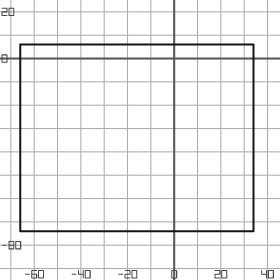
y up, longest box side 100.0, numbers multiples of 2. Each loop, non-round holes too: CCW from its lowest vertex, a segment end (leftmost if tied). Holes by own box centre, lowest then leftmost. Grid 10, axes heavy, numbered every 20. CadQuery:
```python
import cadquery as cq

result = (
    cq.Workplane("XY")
    .moveTo(-66.0, -74.0)
    .lineTo(34.0, -74.0)
    .lineTo(34.0, 6.0)
    .lineTo(-66.0, 6.0)
    .close()
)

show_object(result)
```